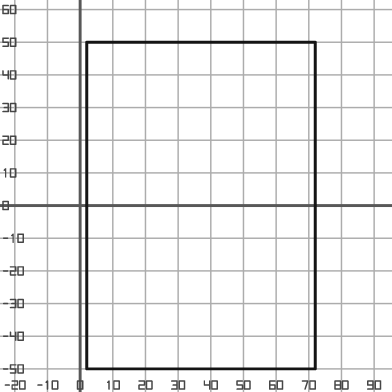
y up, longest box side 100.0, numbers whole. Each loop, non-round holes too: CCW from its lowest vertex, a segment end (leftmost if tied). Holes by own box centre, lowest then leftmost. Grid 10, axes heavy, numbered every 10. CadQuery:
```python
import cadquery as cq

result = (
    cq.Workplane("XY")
    .moveTo(2.0, -50.0)
    .lineTo(72.0, -50.0)
    .lineTo(72.0, 50.0)
    .lineTo(2.0, 50.0)
    .close()
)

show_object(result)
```